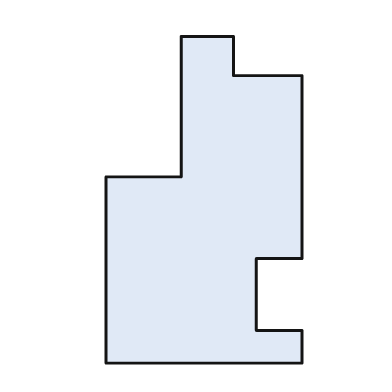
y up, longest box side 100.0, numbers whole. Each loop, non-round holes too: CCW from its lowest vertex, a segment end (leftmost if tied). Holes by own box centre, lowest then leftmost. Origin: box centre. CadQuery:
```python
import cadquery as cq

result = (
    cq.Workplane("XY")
    .moveTo(-30.0, -50.0)
    .lineTo(30.0, -50.0)
    .lineTo(30.0, -40.0)
    .lineTo(16.0, -40.0)
    .lineTo(16.0, -18.0)
    .lineTo(30.0, -18.0)
    .lineTo(30.0, 38.0)
    .lineTo(9.0, 38.0)
    .lineTo(9.0, 50.0)
    .lineTo(-7.0, 50.0)
    .lineTo(-7.0, 7.0)
    .lineTo(-30.0, 7.0)
    .close()
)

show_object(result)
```